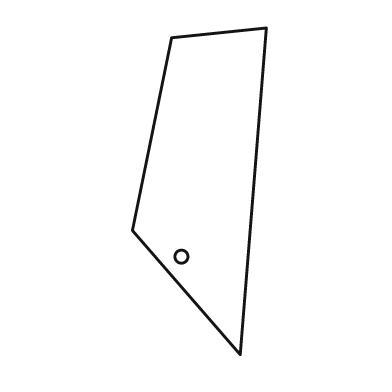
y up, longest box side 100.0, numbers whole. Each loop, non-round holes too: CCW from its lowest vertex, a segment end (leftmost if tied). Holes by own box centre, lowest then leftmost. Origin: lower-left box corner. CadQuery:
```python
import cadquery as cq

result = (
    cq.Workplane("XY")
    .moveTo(33.0, 0.0)
    .lineTo(41.0, 100.0)
    .lineTo(12.0, 97.0)
    .lineTo(0.0, 38.0)
    .close()
    .moveTo(15.0, 30.0)
    .circle(2.0)
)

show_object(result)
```